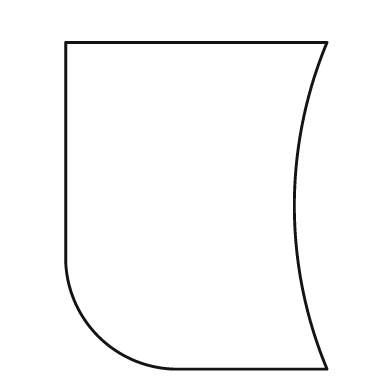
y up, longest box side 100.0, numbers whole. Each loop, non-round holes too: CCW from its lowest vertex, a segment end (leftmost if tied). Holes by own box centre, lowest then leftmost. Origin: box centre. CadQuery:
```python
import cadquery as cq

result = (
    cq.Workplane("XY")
    .moveTo(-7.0, -50.0)
    .lineTo(40.0, -50.0)
    .threePointArc((30.0, 0.0), (40.0, 50.0))
    .lineTo(-40.0, 50.0)
    .lineTo(-40.0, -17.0)
    .threePointArc((-30.0, -40.0), (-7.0, -50.0))
    .close()
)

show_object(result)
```